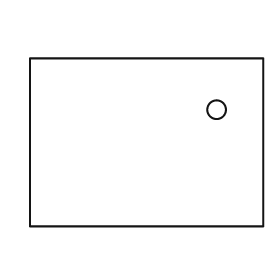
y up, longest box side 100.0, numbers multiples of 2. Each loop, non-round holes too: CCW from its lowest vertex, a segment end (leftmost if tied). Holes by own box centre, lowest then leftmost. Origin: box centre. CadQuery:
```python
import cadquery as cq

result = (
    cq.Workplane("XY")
    .moveTo(-50.0, -36.0)
    .lineTo(50.0, -36.0)
    .lineTo(50.0, 36.0)
    .lineTo(-50.0, 36.0)
    .close()
    .moveTo(30.0, 14.0)
    .circle(4.0)
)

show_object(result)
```